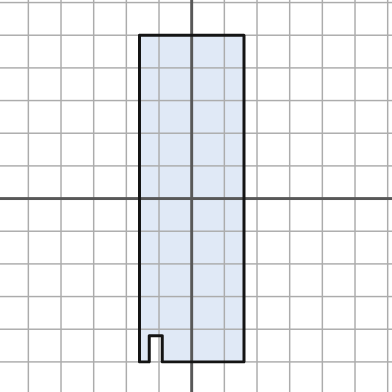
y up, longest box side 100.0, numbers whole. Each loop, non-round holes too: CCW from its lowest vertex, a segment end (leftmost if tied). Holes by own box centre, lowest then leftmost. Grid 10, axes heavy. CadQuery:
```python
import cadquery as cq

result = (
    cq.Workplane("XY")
    .moveTo(-16.0, -50.0)
    .lineTo(-13.0, -50.0)
    .lineTo(-13.0, -42.0)
    .lineTo(-9.0, -42.0)
    .lineTo(-9.0, -50.0)
    .lineTo(16.0, -50.0)
    .lineTo(16.0, 50.0)
    .lineTo(-16.0, 50.0)
    .close()
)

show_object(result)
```